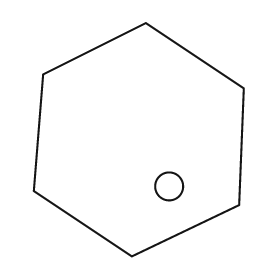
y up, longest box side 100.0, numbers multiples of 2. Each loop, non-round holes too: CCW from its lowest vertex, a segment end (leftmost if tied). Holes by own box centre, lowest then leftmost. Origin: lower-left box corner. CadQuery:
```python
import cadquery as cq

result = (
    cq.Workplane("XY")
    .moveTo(42.0, 0.0)
    .lineTo(88.0, 22.0)
    .lineTo(90.0, 72.0)
    .lineTo(48.0, 100.0)
    .lineTo(4.0, 78.0)
    .lineTo(0.0, 28.0)
    .close()
    .moveTo(58.0, 30.0)
    .circle(6.0)
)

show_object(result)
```